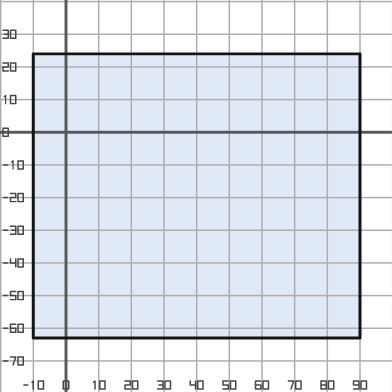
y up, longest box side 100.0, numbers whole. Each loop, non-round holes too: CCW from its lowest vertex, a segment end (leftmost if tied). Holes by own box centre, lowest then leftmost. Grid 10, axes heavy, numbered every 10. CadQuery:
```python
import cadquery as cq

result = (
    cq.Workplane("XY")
    .moveTo(-10.0, -63.0)
    .lineTo(90.0, -63.0)
    .lineTo(90.0, 24.0)
    .lineTo(-10.0, 24.0)
    .close()
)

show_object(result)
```